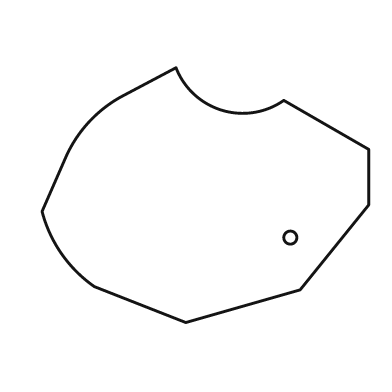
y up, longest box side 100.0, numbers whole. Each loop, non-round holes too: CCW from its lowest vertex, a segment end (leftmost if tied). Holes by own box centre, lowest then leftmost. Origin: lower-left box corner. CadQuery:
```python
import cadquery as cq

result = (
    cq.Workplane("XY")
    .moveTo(44.0, 0.0)
    .lineTo(79.0, 10.0)
    .lineTo(100.0, 36.0)
    .lineTo(100.0, 53.0)
    .lineTo(74.0, 68.0)
    .threePointArc((55.0, 65.0), (41.0, 78.0))
    .lineTo(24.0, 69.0)
    .threePointArc((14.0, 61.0), (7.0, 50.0))
    .lineTo(0.0, 34.0)
    .threePointArc((6.0, 21.0), (16.0, 11.0))
    .close()
    .moveTo(76.0, 26.0)
    .circle(2.0)
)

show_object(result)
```